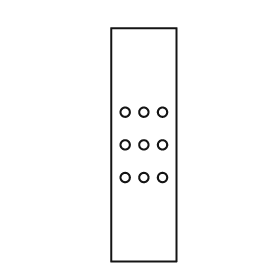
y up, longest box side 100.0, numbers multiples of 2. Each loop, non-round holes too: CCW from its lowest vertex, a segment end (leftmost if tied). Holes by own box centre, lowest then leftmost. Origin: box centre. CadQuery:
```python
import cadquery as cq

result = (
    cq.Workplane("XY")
    .moveTo(-14.0, -50.0)
    .lineTo(14.0, -50.0)
    .lineTo(14.0, 50.0)
    .lineTo(-14.0, 50.0)
    .close()
    .moveTo(-8.0, -14.0)
    .circle(2.0)
    .moveTo(0.0, -14.0)
    .circle(2.0)
    .moveTo(8.0, -14.0)
    .circle(2.0)
    .moveTo(-8.0, 0.0)
    .circle(2.0)
    .moveTo(0.0, 0.0)
    .circle(2.0)
    .moveTo(8.0, 0.0)
    .circle(2.0)
    .moveTo(-8.0, 14.0)
    .circle(2.0)
    .moveTo(0.0, 14.0)
    .circle(2.0)
    .moveTo(8.0, 14.0)
    .circle(2.0)
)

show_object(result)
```